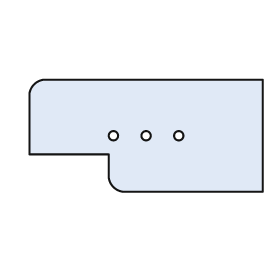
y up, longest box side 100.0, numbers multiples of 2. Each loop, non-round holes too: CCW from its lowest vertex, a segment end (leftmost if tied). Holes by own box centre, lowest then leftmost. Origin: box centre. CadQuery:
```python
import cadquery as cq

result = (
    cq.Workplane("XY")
    .moveTo(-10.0, -24.0)
    .lineTo(50.0, -24.0)
    .lineTo(50.0, 24.0)
    .lineTo(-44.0, 24.0)
    .threePointArc((-48.0, 22.0), (-50.0, 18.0))
    .lineTo(-50.0, -8.0)
    .lineTo(-16.0, -8.0)
    .lineTo(-16.0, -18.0)
    .threePointArc((-14.0, -22.0), (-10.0, -24.0))
    .close()
    .moveTo(-14.0, 0.0)
    .circle(2.0)
    .moveTo(0.0, 0.0)
    .circle(2.0)
    .moveTo(14.0, 0.0)
    .circle(2.0)
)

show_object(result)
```